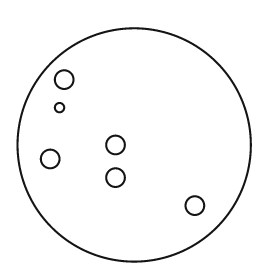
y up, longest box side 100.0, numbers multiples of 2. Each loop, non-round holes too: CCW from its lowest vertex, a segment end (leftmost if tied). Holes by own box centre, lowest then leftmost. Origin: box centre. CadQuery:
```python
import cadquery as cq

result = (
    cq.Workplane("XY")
    .moveTo(0.0, 0.0)
    .circle(50.0)
    .moveTo(26.0, -26.0)
    .circle(4.0)
    .moveTo(-8.0, -14.0)
    .circle(4.0)
    .moveTo(-36.0, -6.0)
    .circle(4.0)
    .moveTo(-8.0, 0.0)
    .circle(4.0)
    .moveTo(-32.0, 16.0)
    .circle(2.0)
    .moveTo(-30.0, 28.0)
    .circle(4.0)
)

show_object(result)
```